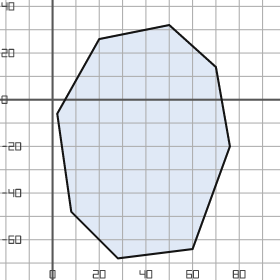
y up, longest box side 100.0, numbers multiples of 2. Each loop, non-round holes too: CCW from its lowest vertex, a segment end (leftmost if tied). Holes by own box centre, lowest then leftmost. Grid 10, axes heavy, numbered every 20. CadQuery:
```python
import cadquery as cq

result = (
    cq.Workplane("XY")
    .moveTo(28.0, -68.0)
    .lineTo(60.0, -64.0)
    .lineTo(76.0, -20.0)
    .lineTo(70.0, 14.0)
    .lineTo(50.0, 32.0)
    .lineTo(20.0, 26.0)
    .lineTo(2.0, -6.0)
    .lineTo(8.0, -48.0)
    .close()
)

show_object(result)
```